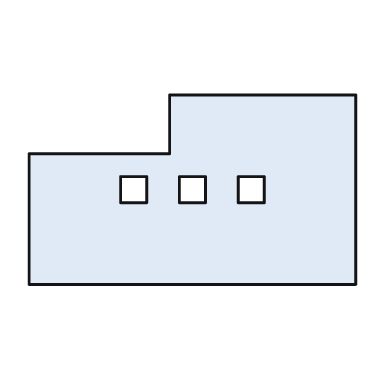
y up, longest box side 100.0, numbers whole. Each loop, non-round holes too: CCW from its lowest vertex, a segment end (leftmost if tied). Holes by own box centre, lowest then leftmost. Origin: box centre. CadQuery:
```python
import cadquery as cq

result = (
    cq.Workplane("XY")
    .moveTo(-50.0, -29.0)
    .lineTo(50.0, -29.0)
    .lineTo(50.0, 29.0)
    .lineTo(-7.0, 29.0)
    .lineTo(-7.0, 11.0)
    .lineTo(-50.0, 11.0)
    .close()
    .moveTo(-22.0, -4.0)
    .lineTo(-14.0, -4.0)
    .lineTo(-14.0, 4.0)
    .lineTo(-22.0, 4.0)
    .close()
    .moveTo(-4.0, -4.0)
    .lineTo(4.0, -4.0)
    .lineTo(4.0, 4.0)
    .lineTo(-4.0, 4.0)
    .close()
    .moveTo(14.0, -4.0)
    .lineTo(22.0, -4.0)
    .lineTo(22.0, 4.0)
    .lineTo(14.0, 4.0)
    .close()
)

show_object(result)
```